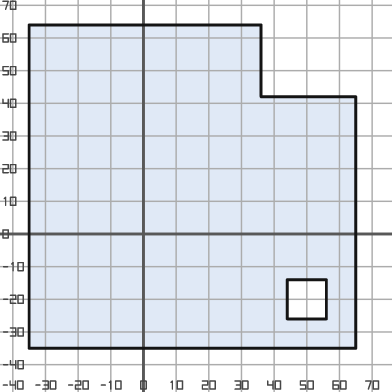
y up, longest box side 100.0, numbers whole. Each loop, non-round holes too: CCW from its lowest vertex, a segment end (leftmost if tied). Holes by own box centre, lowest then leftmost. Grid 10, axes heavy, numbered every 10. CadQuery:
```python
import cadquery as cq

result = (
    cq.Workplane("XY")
    .moveTo(-35.0, -35.0)
    .lineTo(65.0, -35.0)
    .lineTo(65.0, 42.0)
    .lineTo(36.0, 42.0)
    .lineTo(36.0, 64.0)
    .lineTo(-35.0, 64.0)
    .close()
    .moveTo(44.0, -26.0)
    .lineTo(56.0, -26.0)
    .lineTo(56.0, -14.0)
    .lineTo(44.0, -14.0)
    .close()
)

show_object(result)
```